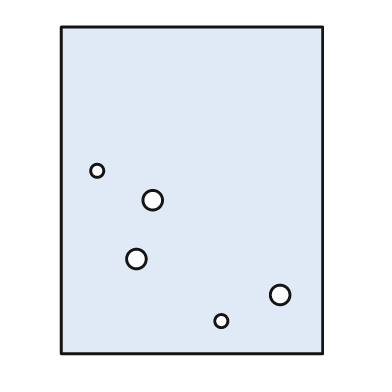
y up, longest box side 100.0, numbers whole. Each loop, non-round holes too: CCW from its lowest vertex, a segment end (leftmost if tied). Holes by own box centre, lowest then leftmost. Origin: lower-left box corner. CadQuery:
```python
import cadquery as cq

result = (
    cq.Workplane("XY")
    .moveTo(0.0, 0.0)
    .lineTo(80.0, 0.0)
    .lineTo(80.0, 100.0)
    .lineTo(0.0, 100.0)
    .close()
    .moveTo(49.0, 10.0)
    .circle(2.0)
    .moveTo(67.0, 18.0)
    .circle(3.0)
    .moveTo(23.0, 29.0)
    .circle(3.0)
    .moveTo(28.0, 47.0)
    .circle(3.0)
    .moveTo(11.0, 56.0)
    .circle(2.0)
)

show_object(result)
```